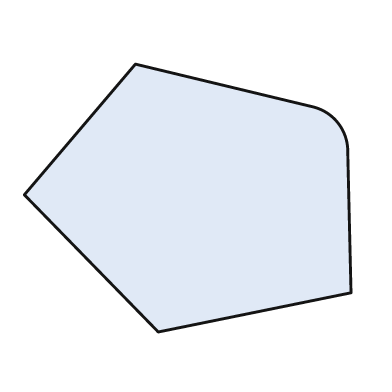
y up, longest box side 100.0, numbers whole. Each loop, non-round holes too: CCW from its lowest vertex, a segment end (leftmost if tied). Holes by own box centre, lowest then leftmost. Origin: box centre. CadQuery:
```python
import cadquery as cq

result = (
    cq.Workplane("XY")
    .moveTo(-9.0, -41.0)
    .lineTo(50.0, -29.0)
    .lineTo(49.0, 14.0)
    .threePointArc((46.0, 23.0), (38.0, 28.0))
    .lineTo(-16.0, 41.0)
    .lineTo(-50.0, 1.0)
    .close()
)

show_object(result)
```